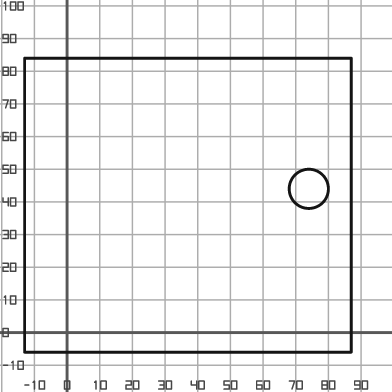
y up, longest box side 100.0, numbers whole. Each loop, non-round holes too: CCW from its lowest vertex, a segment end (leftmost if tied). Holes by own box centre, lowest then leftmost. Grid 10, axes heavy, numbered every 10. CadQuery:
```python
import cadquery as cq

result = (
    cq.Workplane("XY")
    .moveTo(-13.0, -6.0)
    .lineTo(87.0, -6.0)
    .lineTo(87.0, 84.0)
    .lineTo(-13.0, 84.0)
    .close()
    .moveTo(74.0, 44.0)
    .circle(6.0)
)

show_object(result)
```